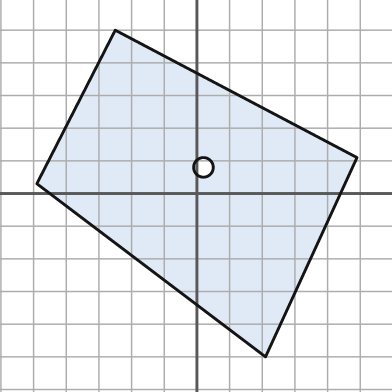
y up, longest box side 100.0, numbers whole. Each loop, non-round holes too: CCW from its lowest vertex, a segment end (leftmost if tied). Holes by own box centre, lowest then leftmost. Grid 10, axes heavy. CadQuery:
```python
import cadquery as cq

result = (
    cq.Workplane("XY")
    .moveTo(21.0, -50.0)
    .lineTo(49.0, 11.0)
    .lineTo(-25.0, 50.0)
    .lineTo(-49.0, 3.0)
    .close()
    .moveTo(2.0, 8.0)
    .circle(3.0)
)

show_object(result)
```